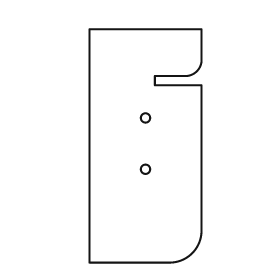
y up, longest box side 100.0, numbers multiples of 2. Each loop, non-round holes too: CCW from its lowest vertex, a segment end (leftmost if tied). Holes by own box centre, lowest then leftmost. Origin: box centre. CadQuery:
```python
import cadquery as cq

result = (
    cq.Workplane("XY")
    .moveTo(-24.0, -50.0)
    .lineTo(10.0, -50.0)
    .threePointArc((20.0, -46.0), (24.0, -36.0))
    .lineTo(24.0, 26.0)
    .lineTo(4.0, 26.0)
    .lineTo(4.0, 30.0)
    .lineTo(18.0, 30.0)
    .threePointArc((22.0, 32.0), (24.0, 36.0))
    .lineTo(24.0, 50.0)
    .lineTo(-24.0, 50.0)
    .close()
    .moveTo(0.0, -10.0)
    .circle(2.0)
    .moveTo(0.0, 12.0)
    .circle(2.0)
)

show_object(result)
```